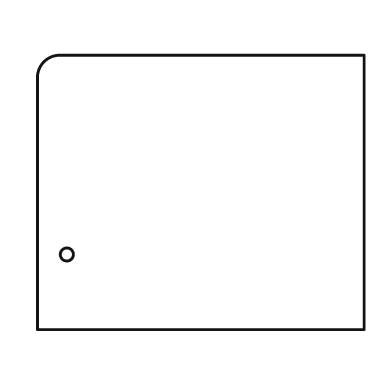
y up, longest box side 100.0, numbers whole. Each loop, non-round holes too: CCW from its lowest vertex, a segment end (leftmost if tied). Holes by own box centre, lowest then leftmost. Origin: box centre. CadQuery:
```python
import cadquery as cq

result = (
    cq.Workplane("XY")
    .moveTo(-50.0, -42.0)
    .lineTo(50.0, -42.0)
    .lineTo(50.0, 42.0)
    .lineTo(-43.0, 42.0)
    .threePointArc((-48.0, 40.0), (-50.0, 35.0))
    .close()
    .moveTo(-41.0, -19.0)
    .circle(2.0)
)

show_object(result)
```